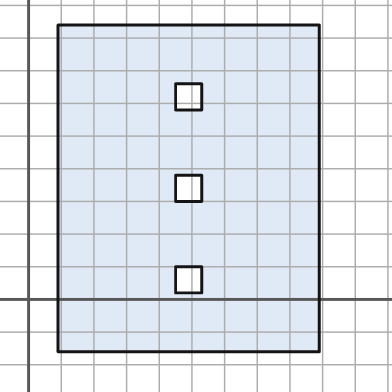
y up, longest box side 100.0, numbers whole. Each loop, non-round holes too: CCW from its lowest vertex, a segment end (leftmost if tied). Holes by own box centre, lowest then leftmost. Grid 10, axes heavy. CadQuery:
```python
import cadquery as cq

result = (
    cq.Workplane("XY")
    .moveTo(9.0, -16.0)
    .lineTo(89.0, -16.0)
    .lineTo(89.0, 84.0)
    .lineTo(9.0, 84.0)
    .close()
    .moveTo(45.0, 2.0)
    .lineTo(53.0, 2.0)
    .lineTo(53.0, 10.0)
    .lineTo(45.0, 10.0)
    .close()
    .moveTo(45.0, 30.0)
    .lineTo(53.0, 30.0)
    .lineTo(53.0, 38.0)
    .lineTo(45.0, 38.0)
    .close()
    .moveTo(45.0, 58.0)
    .lineTo(53.0, 58.0)
    .lineTo(53.0, 66.0)
    .lineTo(45.0, 66.0)
    .close()
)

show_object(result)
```